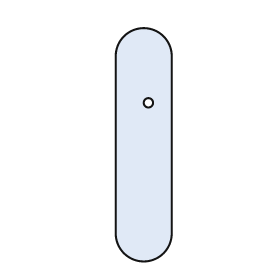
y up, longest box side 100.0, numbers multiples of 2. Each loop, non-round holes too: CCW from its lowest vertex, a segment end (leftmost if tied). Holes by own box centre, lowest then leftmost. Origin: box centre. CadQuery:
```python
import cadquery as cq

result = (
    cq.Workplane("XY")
    .moveTo(-12.0, -38.0)
    .threePointArc((0.0, -50.0), (12.0, -38.0))
    .lineTo(12.0, 38.0)
    .threePointArc((0.0, 50.0), (-12.0, 38.0))
    .close()
    .moveTo(2.0, 18.0)
    .circle(2.0)
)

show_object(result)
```